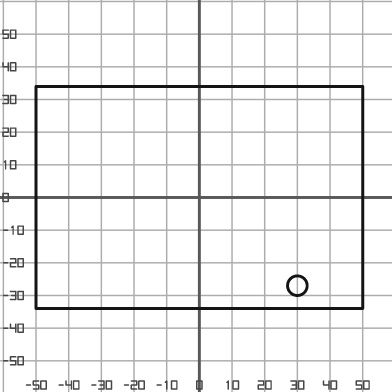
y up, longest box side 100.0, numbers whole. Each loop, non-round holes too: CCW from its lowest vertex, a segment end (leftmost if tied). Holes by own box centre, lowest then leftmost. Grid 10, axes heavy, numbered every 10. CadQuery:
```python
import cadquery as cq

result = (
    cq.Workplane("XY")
    .moveTo(-50.0, -34.0)
    .lineTo(50.0, -34.0)
    .lineTo(50.0, 34.0)
    .lineTo(-50.0, 34.0)
    .close()
    .moveTo(30.0, -27.0)
    .circle(3.0)
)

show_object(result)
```